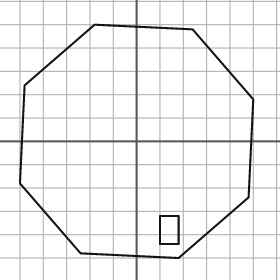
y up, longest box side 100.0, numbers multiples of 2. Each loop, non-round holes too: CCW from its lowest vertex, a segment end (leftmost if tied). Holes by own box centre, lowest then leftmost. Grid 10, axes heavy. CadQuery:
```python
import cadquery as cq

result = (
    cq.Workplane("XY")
    .moveTo(18.0, -50.0)
    .lineTo(48.0, -24.0)
    .lineTo(50.0, 18.0)
    .lineTo(24.0, 48.0)
    .lineTo(-18.0, 50.0)
    .lineTo(-48.0, 24.0)
    .lineTo(-50.0, -18.0)
    .lineTo(-24.0, -48.0)
    .close()
    .moveTo(10.0, -44.0)
    .lineTo(18.0, -44.0)
    .lineTo(18.0, -32.0)
    .lineTo(10.0, -32.0)
    .close()
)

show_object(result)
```